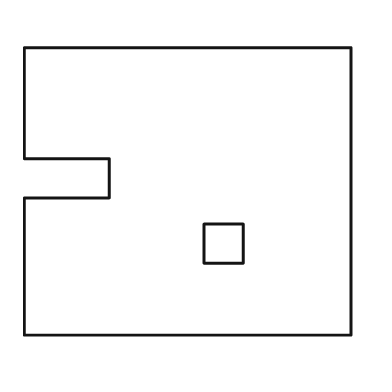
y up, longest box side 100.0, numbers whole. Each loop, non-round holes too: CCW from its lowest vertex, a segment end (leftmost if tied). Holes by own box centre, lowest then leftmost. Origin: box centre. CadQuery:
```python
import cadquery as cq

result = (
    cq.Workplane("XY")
    .moveTo(-50.0, -44.0)
    .lineTo(50.0, -44.0)
    .lineTo(50.0, 44.0)
    .lineTo(-50.0, 44.0)
    .lineTo(-50.0, 10.0)
    .lineTo(-24.0, 10.0)
    .lineTo(-24.0, -2.0)
    .lineTo(-50.0, -2.0)
    .close()
    .moveTo(5.0, -22.0)
    .lineTo(17.0, -22.0)
    .lineTo(17.0, -10.0)
    .lineTo(5.0, -10.0)
    .close()
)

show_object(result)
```